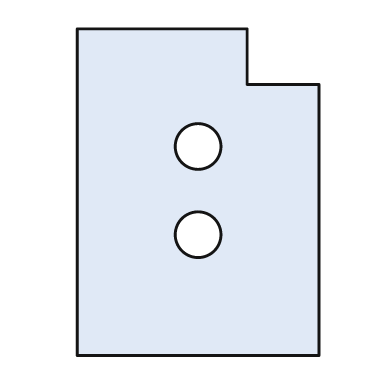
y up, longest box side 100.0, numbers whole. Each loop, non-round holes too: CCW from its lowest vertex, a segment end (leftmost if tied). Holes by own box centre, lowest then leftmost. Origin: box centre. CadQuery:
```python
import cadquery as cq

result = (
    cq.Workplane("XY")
    .moveTo(-37.0, -50.0)
    .lineTo(37.0, -50.0)
    .lineTo(37.0, 33.0)
    .lineTo(15.0, 33.0)
    .lineTo(15.0, 50.0)
    .lineTo(-37.0, 50.0)
    .close()
    .moveTo(0.0, -13.0)
    .circle(7.0)
    .moveTo(0.0, 14.0)
    .circle(7.0)
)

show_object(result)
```